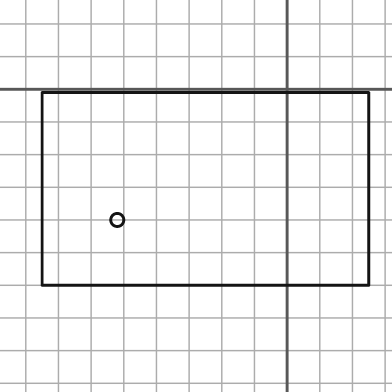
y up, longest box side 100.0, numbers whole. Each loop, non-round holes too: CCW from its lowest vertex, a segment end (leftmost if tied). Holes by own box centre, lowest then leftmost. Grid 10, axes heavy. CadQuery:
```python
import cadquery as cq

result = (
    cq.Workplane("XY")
    .moveTo(-75.0, -60.0)
    .lineTo(25.0, -60.0)
    .lineTo(25.0, -1.0)
    .lineTo(-75.0, -1.0)
    .close()
    .moveTo(-52.0, -40.0)
    .circle(2.0)
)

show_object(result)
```